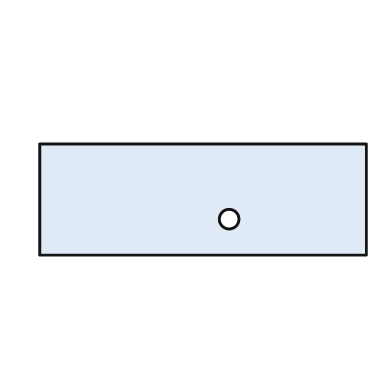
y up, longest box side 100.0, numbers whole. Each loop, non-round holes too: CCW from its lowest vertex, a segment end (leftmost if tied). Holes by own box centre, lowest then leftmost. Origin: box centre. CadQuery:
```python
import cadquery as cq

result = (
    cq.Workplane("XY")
    .moveTo(-50.0, -17.0)
    .lineTo(50.0, -17.0)
    .lineTo(50.0, 17.0)
    .lineTo(-50.0, 17.0)
    .close()
    .moveTo(8.0, -6.0)
    .circle(3.0)
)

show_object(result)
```